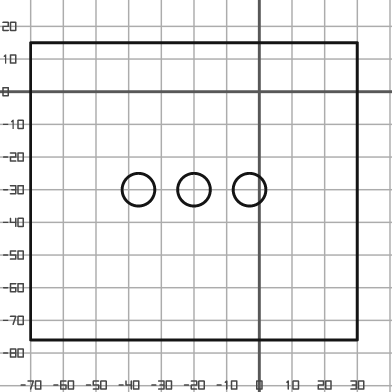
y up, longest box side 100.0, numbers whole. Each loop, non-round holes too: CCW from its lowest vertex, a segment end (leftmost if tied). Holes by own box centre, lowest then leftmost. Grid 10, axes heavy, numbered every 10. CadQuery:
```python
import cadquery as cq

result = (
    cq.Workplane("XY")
    .moveTo(-70.0, -76.0)
    .lineTo(30.0, -76.0)
    .lineTo(30.0, 15.0)
    .lineTo(-70.0, 15.0)
    .close()
    .moveTo(-37.0, -30.0)
    .circle(5.0)
    .moveTo(-20.0, -30.0)
    .circle(5.0)
    .moveTo(-3.0, -30.0)
    .circle(5.0)
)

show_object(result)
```